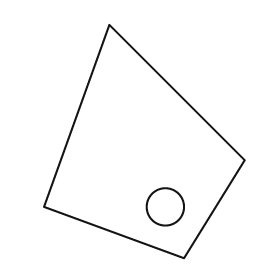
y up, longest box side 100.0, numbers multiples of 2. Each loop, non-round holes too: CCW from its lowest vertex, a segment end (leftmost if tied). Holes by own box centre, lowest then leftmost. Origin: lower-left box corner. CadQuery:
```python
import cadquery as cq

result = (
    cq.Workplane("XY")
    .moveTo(60.0, 0.0)
    .lineTo(86.0, 42.0)
    .lineTo(28.0, 100.0)
    .lineTo(0.0, 22.0)
    .close()
    .moveTo(52.0, 22.0)
    .circle(8.0)
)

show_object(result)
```